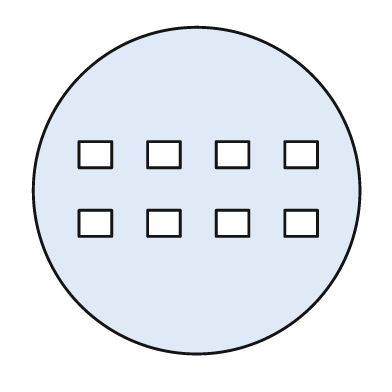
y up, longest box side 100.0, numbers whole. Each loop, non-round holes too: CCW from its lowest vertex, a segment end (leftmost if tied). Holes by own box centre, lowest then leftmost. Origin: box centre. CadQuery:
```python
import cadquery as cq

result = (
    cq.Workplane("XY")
    .moveTo(0.0, 0.0)
    .circle(50.0)
    .moveTo(-36.0, -14.0)
    .lineTo(-26.0, -14.0)
    .lineTo(-26.0, -6.0)
    .lineTo(-36.0, -6.0)
    .close()
    .moveTo(-15.0, -14.0)
    .lineTo(-5.0, -14.0)
    .lineTo(-5.0, -6.0)
    .lineTo(-15.0, -6.0)
    .close()
    .moveTo(6.0, -14.0)
    .lineTo(16.0, -14.0)
    .lineTo(16.0, -6.0)
    .lineTo(6.0, -6.0)
    .close()
    .moveTo(27.0, -14.0)
    .lineTo(37.0, -14.0)
    .lineTo(37.0, -6.0)
    .lineTo(27.0, -6.0)
    .close()
    .moveTo(-36.0, 7.0)
    .lineTo(-26.0, 7.0)
    .lineTo(-26.0, 15.0)
    .lineTo(-36.0, 15.0)
    .close()
    .moveTo(-15.0, 7.0)
    .lineTo(-5.0, 7.0)
    .lineTo(-5.0, 15.0)
    .lineTo(-15.0, 15.0)
    .close()
    .moveTo(6.0, 7.0)
    .lineTo(16.0, 7.0)
    .lineTo(16.0, 15.0)
    .lineTo(6.0, 15.0)
    .close()
    .moveTo(27.0, 7.0)
    .lineTo(37.0, 7.0)
    .lineTo(37.0, 15.0)
    .lineTo(27.0, 15.0)
    .close()
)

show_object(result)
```